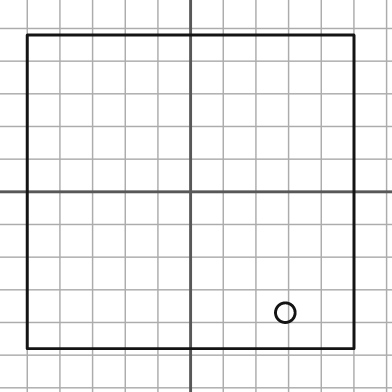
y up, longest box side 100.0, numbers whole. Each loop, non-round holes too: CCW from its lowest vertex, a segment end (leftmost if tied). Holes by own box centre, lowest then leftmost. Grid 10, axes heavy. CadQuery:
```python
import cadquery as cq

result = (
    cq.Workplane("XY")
    .moveTo(-50.0, -48.0)
    .lineTo(50.0, -48.0)
    .lineTo(50.0, 48.0)
    .lineTo(-50.0, 48.0)
    .close()
    .moveTo(29.0, -37.0)
    .circle(3.0)
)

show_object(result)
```